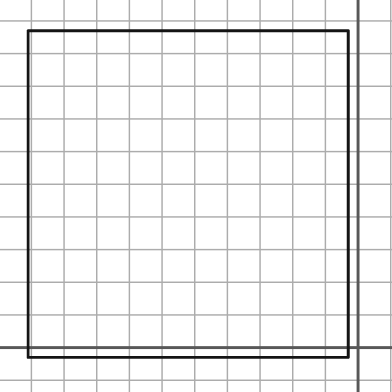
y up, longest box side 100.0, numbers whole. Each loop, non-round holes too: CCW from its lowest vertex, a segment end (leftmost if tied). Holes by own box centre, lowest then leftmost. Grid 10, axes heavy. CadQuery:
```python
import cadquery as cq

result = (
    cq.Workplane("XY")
    .moveTo(-101.0, -3.0)
    .lineTo(-3.0, -3.0)
    .lineTo(-3.0, 97.0)
    .lineTo(-101.0, 97.0)
    .close()
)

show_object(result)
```